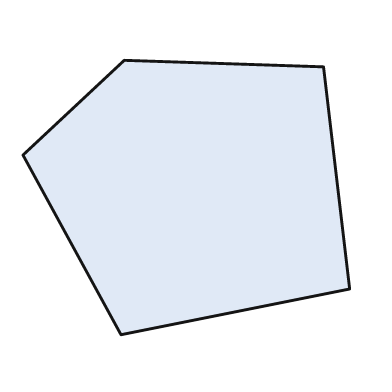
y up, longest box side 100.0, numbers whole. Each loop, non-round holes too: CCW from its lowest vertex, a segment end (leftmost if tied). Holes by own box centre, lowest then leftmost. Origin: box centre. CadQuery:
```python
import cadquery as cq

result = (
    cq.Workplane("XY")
    .moveTo(-20.0, -42.0)
    .lineTo(50.0, -28.0)
    .lineTo(42.0, 40.0)
    .lineTo(-19.0, 42.0)
    .lineTo(-50.0, 13.0)
    .close()
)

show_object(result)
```